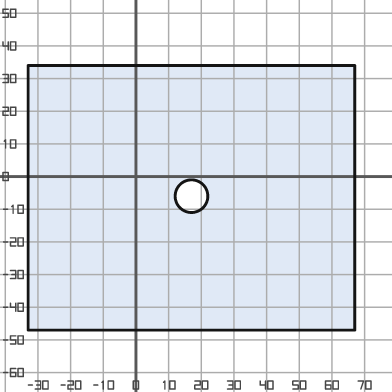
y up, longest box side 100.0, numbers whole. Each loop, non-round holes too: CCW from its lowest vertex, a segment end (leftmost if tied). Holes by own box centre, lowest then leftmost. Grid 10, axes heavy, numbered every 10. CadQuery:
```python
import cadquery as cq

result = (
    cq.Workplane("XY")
    .moveTo(-33.0, -47.0)
    .lineTo(67.0, -47.0)
    .lineTo(67.0, 34.0)
    .lineTo(-33.0, 34.0)
    .close()
    .moveTo(17.0, -6.0)
    .circle(5.0)
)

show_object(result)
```